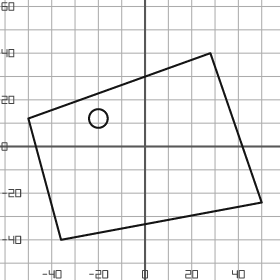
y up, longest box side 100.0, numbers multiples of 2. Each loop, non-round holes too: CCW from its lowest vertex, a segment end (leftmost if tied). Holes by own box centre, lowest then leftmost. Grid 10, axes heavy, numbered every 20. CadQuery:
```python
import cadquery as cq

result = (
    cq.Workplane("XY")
    .moveTo(-36.0, -40.0)
    .lineTo(50.0, -24.0)
    .lineTo(28.0, 40.0)
    .lineTo(-50.0, 12.0)
    .close()
    .moveTo(-20.0, 12.0)
    .circle(4.0)
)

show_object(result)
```